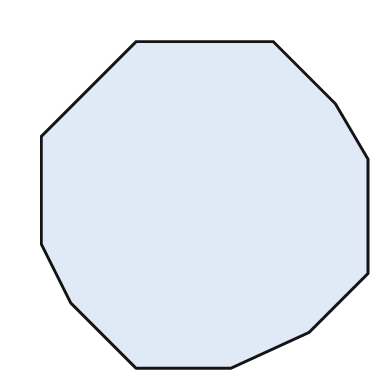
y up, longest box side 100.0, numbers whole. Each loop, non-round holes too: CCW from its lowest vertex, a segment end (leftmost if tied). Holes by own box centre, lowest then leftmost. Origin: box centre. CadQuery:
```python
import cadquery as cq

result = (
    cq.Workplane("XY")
    .moveTo(-21.0, -50.0)
    .lineTo(8.0, -50.0)
    .lineTo(32.0, -39.0)
    .lineTo(50.0, -21.0)
    .lineTo(50.0, 14.0)
    .lineTo(40.0, 31.0)
    .lineTo(21.0, 50.0)
    .lineTo(-21.0, 50.0)
    .lineTo(-50.0, 21.0)
    .lineTo(-50.0, -12.0)
    .lineTo(-41.0, -30.0)
    .close()
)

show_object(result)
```